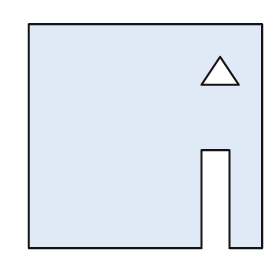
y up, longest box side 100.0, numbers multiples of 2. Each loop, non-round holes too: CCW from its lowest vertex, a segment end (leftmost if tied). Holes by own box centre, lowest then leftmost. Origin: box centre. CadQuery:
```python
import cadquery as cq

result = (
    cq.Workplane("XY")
    .moveTo(-50.0, -48.0)
    .lineTo(24.0, -48.0)
    .lineTo(24.0, -6.0)
    .lineTo(36.0, -6.0)
    .lineTo(36.0, -48.0)
    .lineTo(50.0, -48.0)
    .lineTo(50.0, 48.0)
    .lineTo(-50.0, 48.0)
    .close()
    .moveTo(24.0, 22.0)
    .lineTo(40.0, 22.0)
    .lineTo(32.0, 34.0)
    .close()
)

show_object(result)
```